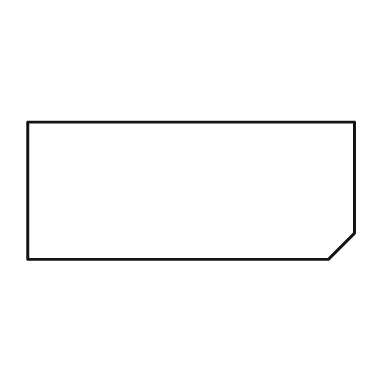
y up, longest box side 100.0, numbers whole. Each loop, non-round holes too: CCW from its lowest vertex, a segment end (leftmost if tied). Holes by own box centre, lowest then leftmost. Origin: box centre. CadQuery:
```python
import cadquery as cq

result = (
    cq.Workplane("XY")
    .moveTo(-50.0, -21.0)
    .lineTo(42.0, -21.0)
    .lineTo(50.0, -13.0)
    .lineTo(50.0, 21.0)
    .lineTo(-50.0, 21.0)
    .close()
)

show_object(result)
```